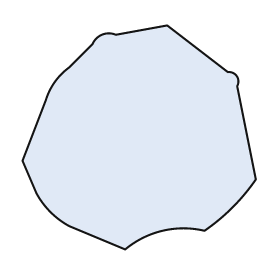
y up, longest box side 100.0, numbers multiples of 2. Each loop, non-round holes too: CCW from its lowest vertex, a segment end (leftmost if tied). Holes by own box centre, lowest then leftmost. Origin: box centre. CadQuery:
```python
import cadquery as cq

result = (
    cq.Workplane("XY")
    .moveTo(-6.0, -48.0)
    .threePointArc((10.0, -40.0), (28.0, -40.0))
    .threePointArc((40.0, -30.0), (50.0, -18.0))
    .lineTo(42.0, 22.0)
    .threePointArc((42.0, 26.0), (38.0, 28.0))
    .lineTo(12.0, 48.0)
    .lineTo(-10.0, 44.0)
    .threePointArc((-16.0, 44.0), (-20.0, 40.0))
    .lineTo(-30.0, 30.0)
    .threePointArc((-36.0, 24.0), (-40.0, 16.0))
    .lineTo(-50.0, -10.0)
    .lineTo(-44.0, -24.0)
    .threePointArc((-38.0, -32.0), (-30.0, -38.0))
    .close()
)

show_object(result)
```